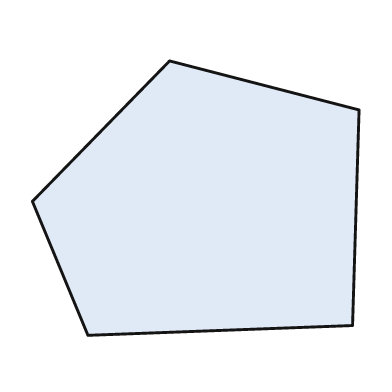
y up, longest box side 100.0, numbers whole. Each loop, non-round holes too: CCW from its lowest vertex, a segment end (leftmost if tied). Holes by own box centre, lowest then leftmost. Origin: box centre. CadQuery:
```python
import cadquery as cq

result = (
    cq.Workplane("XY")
    .moveTo(-33.0, -42.0)
    .lineTo(48.0, -39.0)
    .lineTo(50.0, 27.0)
    .lineTo(-8.0, 42.0)
    .lineTo(-50.0, -1.0)
    .close()
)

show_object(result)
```